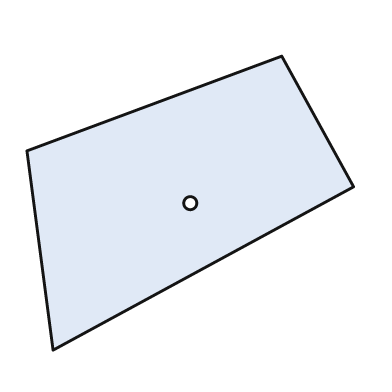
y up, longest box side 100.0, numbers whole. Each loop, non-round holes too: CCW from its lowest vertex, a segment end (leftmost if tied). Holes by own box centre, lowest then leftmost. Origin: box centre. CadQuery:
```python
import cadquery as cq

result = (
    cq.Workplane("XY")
    .moveTo(-42.0, -45.0)
    .lineTo(50.0, 5.0)
    .lineTo(28.0, 45.0)
    .lineTo(-50.0, 16.0)
    .close()
    .moveTo(0.0, 0.0)
    .circle(2.0)
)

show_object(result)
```